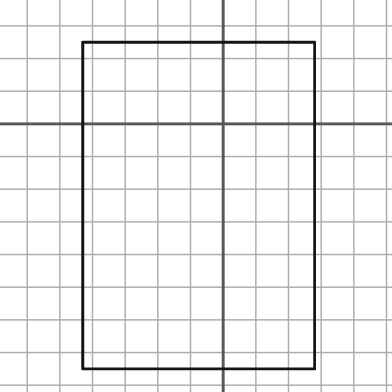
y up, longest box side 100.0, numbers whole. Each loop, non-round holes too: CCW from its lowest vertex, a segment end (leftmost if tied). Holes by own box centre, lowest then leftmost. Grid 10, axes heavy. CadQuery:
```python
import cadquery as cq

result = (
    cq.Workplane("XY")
    .moveTo(-43.0, -75.0)
    .lineTo(28.0, -75.0)
    .lineTo(28.0, 25.0)
    .lineTo(-43.0, 25.0)
    .close()
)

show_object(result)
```